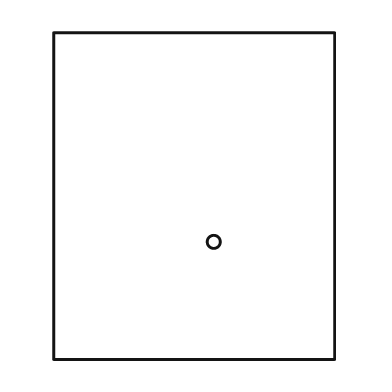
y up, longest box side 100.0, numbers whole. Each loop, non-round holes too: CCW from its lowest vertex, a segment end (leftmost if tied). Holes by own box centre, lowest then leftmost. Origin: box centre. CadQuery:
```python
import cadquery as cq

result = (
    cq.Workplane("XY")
    .moveTo(-43.0, -50.0)
    .lineTo(43.0, -50.0)
    .lineTo(43.0, 50.0)
    .lineTo(-43.0, 50.0)
    .close()
    .moveTo(6.0, -14.0)
    .circle(2.0)
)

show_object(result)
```